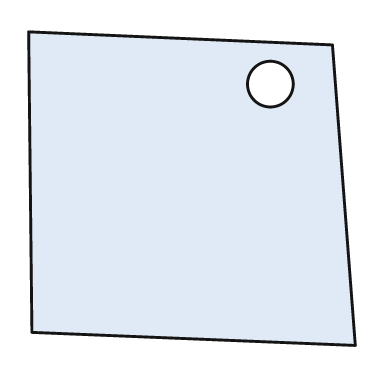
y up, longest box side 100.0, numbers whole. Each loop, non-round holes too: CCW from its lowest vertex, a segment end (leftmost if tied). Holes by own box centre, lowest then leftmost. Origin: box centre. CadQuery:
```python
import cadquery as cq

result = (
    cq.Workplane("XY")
    .moveTo(50.0, -48.0)
    .lineTo(43.0, 44.0)
    .lineTo(-50.0, 48.0)
    .lineTo(-49.0, -44.0)
    .close()
    .moveTo(24.0, 32.0)
    .circle(7.0)
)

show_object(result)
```